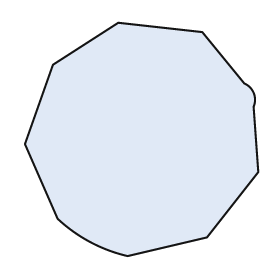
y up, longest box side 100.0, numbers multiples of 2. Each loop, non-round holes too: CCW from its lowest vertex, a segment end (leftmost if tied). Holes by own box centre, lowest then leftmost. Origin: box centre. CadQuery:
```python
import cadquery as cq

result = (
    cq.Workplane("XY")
    .moveTo(-6.0, -50.0)
    .lineTo(28.0, -42.0)
    .lineTo(50.0, -14.0)
    .lineTo(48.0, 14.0)
    .threePointArc((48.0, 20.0), (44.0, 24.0))
    .lineTo(26.0, 46.0)
    .lineTo(-10.0, 50.0)
    .lineTo(-38.0, 32.0)
    .lineTo(-50.0, -2.0)
    .lineTo(-36.0, -34.0)
    .threePointArc((-22.0, -44.0), (-6.0, -50.0))
    .close()
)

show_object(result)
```